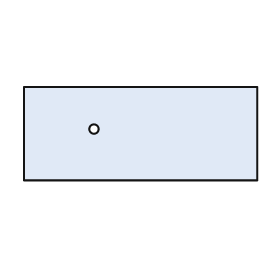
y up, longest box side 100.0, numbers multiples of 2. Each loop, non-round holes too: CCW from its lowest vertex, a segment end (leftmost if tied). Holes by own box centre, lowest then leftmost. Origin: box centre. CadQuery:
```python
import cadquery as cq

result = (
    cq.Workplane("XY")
    .moveTo(-50.0, -20.0)
    .lineTo(50.0, -20.0)
    .lineTo(50.0, 20.0)
    .lineTo(-50.0, 20.0)
    .close()
    .moveTo(-20.0, 2.0)
    .circle(2.0)
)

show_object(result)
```